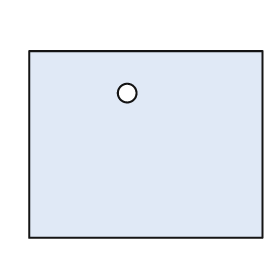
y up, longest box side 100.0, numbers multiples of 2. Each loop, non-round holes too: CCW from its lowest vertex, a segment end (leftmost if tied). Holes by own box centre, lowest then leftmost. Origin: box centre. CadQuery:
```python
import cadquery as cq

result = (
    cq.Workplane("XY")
    .moveTo(-50.0, -40.0)
    .lineTo(50.0, -40.0)
    .lineTo(50.0, 40.0)
    .lineTo(-50.0, 40.0)
    .close()
    .moveTo(-8.0, 22.0)
    .circle(4.0)
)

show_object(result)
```